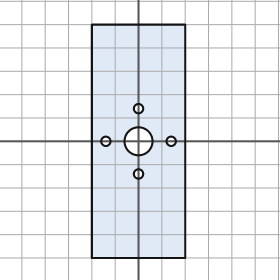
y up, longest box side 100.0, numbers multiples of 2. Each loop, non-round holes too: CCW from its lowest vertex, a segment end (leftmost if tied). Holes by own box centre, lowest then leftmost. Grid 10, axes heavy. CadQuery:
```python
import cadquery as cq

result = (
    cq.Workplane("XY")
    .moveTo(-20.0, -50.0)
    .lineTo(20.0, -50.0)
    .lineTo(20.0, 50.0)
    .lineTo(-20.0, 50.0)
    .close()
    .moveTo(0.0, -14.0)
    .circle(2.0)
    .moveTo(-14.0, 0.0)
    .circle(2.0)
    .moveTo(0.0, 0.0)
    .circle(6.0)
    .moveTo(14.0, 0.0)
    .circle(2.0)
    .moveTo(0.0, 14.0)
    .circle(2.0)
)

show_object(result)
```